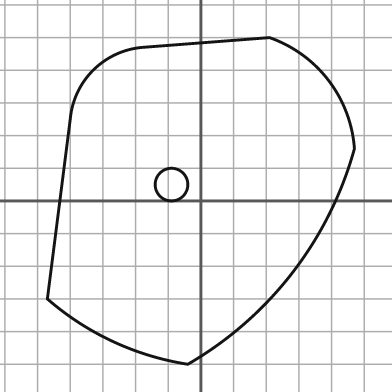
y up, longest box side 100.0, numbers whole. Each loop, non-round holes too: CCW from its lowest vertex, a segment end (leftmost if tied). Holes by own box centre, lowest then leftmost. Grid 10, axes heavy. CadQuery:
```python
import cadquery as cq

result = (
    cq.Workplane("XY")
    .moveTo(-4.0, -50.0)
    .threePointArc((28.0, -22.0), (47.0, 16.0))
    .threePointArc((39.0, 37.0), (21.0, 50.0))
    .lineTo(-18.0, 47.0)
    .threePointArc((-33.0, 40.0), (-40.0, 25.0))
    .lineTo(-47.0, -30.0)
    .threePointArc((-27.0, -43.0), (-4.0, -50.0))
    .close()
    .moveTo(-9.0, 5.0)
    .circle(5.0)
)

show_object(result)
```